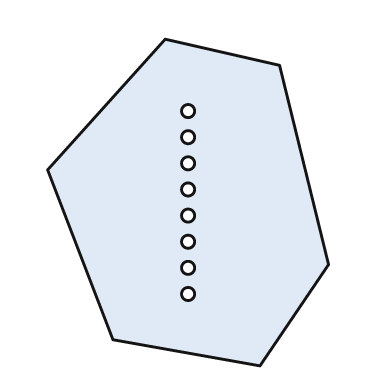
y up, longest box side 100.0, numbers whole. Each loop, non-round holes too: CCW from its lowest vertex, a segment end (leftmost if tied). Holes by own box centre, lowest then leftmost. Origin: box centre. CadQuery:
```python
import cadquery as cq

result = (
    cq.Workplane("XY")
    .moveTo(22.0, -50.0)
    .lineTo(43.0, -19.0)
    .lineTo(28.0, 42.0)
    .lineTo(-7.0, 50.0)
    .lineTo(-43.0, 10.0)
    .lineTo(-23.0, -42.0)
    .close()
    .moveTo(0.0, -28.0)
    .circle(2.0)
    .moveTo(0.0, -20.0)
    .circle(2.0)
    .moveTo(0.0, -12.0)
    .circle(2.0)
    .moveTo(0.0, -4.0)
    .circle(2.0)
    .moveTo(0.0, 4.0)
    .circle(2.0)
    .moveTo(0.0, 12.0)
    .circle(2.0)
    .moveTo(0.0, 20.0)
    .circle(2.0)
    .moveTo(0.0, 28.0)
    .circle(2.0)
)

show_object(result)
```